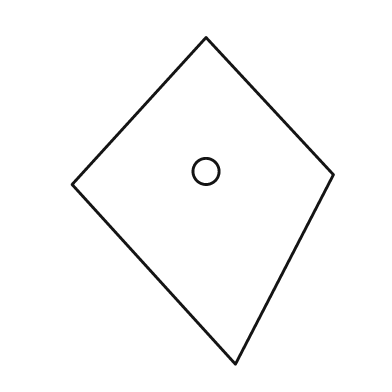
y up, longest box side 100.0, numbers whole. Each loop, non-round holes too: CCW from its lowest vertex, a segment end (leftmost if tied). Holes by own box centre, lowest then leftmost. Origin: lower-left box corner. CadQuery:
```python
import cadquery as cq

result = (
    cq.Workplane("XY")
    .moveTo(50.0, 0.0)
    .lineTo(80.0, 58.0)
    .lineTo(41.0, 100.0)
    .lineTo(0.0, 55.0)
    .close()
    .moveTo(41.0, 59.0)
    .circle(4.0)
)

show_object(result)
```